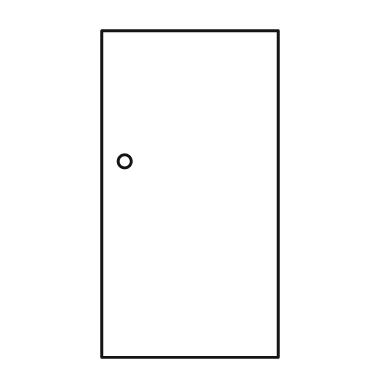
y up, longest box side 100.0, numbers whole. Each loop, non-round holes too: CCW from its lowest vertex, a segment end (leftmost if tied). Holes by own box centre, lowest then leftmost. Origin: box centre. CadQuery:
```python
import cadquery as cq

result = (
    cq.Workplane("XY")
    .moveTo(-27.0, -50.0)
    .lineTo(27.0, -50.0)
    .lineTo(27.0, 50.0)
    .lineTo(-27.0, 50.0)
    .close()
    .moveTo(-20.0, 10.0)
    .circle(2.0)
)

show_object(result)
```